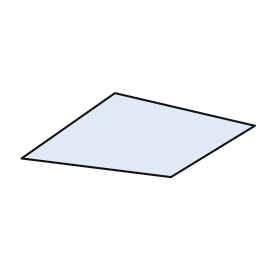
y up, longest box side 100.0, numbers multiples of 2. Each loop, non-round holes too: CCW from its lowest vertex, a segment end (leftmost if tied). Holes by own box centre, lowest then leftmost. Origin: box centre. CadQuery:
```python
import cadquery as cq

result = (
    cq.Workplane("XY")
    .moveTo(14.0, -18.0)
    .lineTo(50.0, 4.0)
    .lineTo(-10.0, 18.0)
    .lineTo(-50.0, -10.0)
    .close()
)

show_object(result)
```